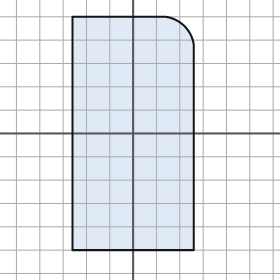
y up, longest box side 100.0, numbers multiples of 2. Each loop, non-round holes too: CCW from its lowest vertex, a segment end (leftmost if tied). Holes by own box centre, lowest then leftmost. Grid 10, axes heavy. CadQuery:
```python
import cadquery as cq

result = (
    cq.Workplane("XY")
    .moveTo(-26.0, -50.0)
    .lineTo(26.0, -50.0)
    .lineTo(26.0, 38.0)
    .threePointArc((22.0, 46.0), (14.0, 50.0))
    .lineTo(-26.0, 50.0)
    .close()
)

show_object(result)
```